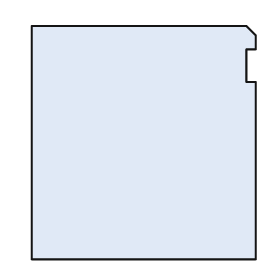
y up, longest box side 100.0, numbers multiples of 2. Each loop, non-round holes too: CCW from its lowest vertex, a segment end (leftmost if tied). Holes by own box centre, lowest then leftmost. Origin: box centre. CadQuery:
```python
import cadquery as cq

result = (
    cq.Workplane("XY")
    .moveTo(-48.0, -50.0)
    .lineTo(48.0, -50.0)
    .lineTo(48.0, 26.0)
    .lineTo(44.0, 26.0)
    .lineTo(44.0, 40.0)
    .lineTo(48.0, 40.0)
    .lineTo(48.0, 46.0)
    .lineTo(44.0, 50.0)
    .lineTo(-48.0, 50.0)
    .close()
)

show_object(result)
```